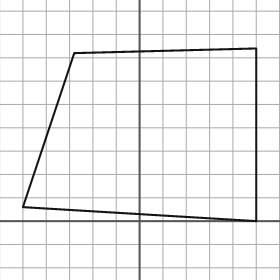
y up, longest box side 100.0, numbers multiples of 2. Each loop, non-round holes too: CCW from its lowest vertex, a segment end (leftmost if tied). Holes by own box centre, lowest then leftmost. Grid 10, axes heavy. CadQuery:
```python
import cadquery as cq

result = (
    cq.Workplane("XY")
    .moveTo(50.0, 0.0)
    .lineTo(50.0, 74.0)
    .lineTo(-28.0, 72.0)
    .lineTo(-50.0, 6.0)
    .close()
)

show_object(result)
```